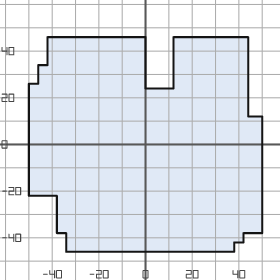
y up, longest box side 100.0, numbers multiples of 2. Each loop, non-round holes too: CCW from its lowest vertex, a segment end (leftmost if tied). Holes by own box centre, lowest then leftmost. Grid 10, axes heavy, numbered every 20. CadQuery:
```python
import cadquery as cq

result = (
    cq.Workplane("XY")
    .moveTo(-34.0, -46.0)
    .lineTo(38.0, -46.0)
    .lineTo(38.0, -42.0)
    .lineTo(42.0, -42.0)
    .lineTo(42.0, -38.0)
    .lineTo(50.0, -38.0)
    .lineTo(50.0, 12.0)
    .lineTo(44.0, 12.0)
    .lineTo(44.0, 46.0)
    .lineTo(12.0, 46.0)
    .lineTo(12.0, 24.0)
    .lineTo(0.0, 24.0)
    .lineTo(0.0, 46.0)
    .lineTo(-42.0, 46.0)
    .lineTo(-42.0, 34.0)
    .lineTo(-46.0, 34.0)
    .lineTo(-46.0, 26.0)
    .lineTo(-50.0, 26.0)
    .lineTo(-50.0, -22.0)
    .lineTo(-38.0, -22.0)
    .lineTo(-38.0, -38.0)
    .lineTo(-34.0, -38.0)
    .close()
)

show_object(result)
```